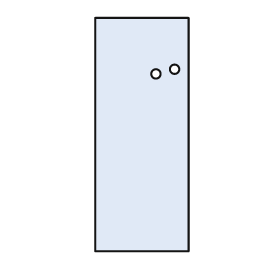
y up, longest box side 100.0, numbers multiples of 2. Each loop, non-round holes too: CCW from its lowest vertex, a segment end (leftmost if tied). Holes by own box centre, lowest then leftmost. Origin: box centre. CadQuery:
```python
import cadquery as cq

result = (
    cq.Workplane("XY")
    .moveTo(-20.0, -50.0)
    .lineTo(20.0, -50.0)
    .lineTo(20.0, 50.0)
    .lineTo(-20.0, 50.0)
    .close()
    .moveTo(6.0, 26.0)
    .circle(2.0)
    .moveTo(14.0, 28.0)
    .circle(2.0)
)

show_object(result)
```